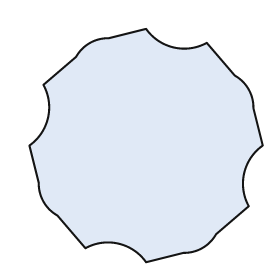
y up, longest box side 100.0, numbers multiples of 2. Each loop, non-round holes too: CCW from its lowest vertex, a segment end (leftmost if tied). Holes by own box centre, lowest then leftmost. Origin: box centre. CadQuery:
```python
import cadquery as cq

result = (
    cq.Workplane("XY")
    .moveTo(0.0, -50.0)
    .lineTo(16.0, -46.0)
    .threePointArc((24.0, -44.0), (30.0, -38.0))
    .lineTo(44.0, -26.0)
    .threePointArc((42.0, -12.0), (50.0, 0.0))
    .lineTo(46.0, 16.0)
    .threePointArc((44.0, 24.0), (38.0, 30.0))
    .lineTo(26.0, 44.0)
    .threePointArc((12.0, 42.0), (0.0, 50.0))
    .lineTo(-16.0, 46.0)
    .threePointArc((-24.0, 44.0), (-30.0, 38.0))
    .lineTo(-44.0, 26.0)
    .threePointArc((-42.0, 12.0), (-50.0, 0.0))
    .lineTo(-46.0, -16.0)
    .threePointArc((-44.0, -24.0), (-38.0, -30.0))
    .lineTo(-26.0, -44.0)
    .threePointArc((-12.0, -42.0), (0.0, -50.0))
    .close()
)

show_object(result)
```